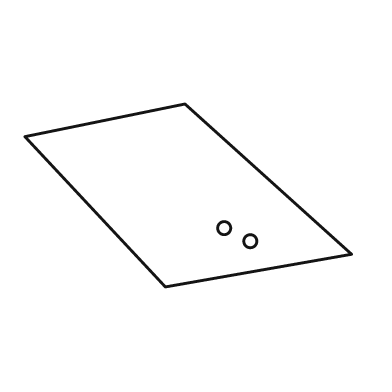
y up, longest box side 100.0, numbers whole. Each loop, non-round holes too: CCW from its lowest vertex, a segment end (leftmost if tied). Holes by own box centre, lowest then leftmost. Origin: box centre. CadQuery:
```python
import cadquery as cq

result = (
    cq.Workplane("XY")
    .moveTo(-7.0, -28.0)
    .lineTo(50.0, -18.0)
    .lineTo(-1.0, 28.0)
    .lineTo(-50.0, 18.0)
    .close()
    .moveTo(19.0, -14.0)
    .circle(2.0)
    .moveTo(11.0, -10.0)
    .circle(2.0)
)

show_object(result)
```